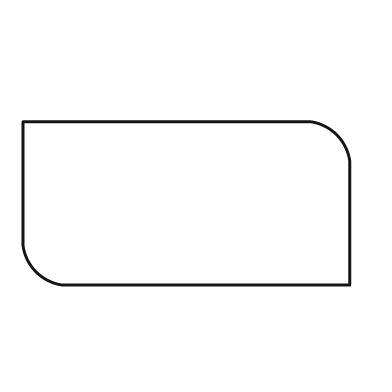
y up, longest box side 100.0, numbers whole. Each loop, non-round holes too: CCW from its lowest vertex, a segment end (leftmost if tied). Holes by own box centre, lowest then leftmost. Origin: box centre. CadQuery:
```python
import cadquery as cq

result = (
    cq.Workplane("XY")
    .moveTo(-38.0, -25.0)
    .lineTo(50.0, -25.0)
    .lineTo(50.0, 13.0)
    .threePointArc((46.0, 21.0), (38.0, 25.0))
    .lineTo(-50.0, 25.0)
    .lineTo(-50.0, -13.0)
    .threePointArc((-46.0, -21.0), (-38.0, -25.0))
    .close()
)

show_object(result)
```